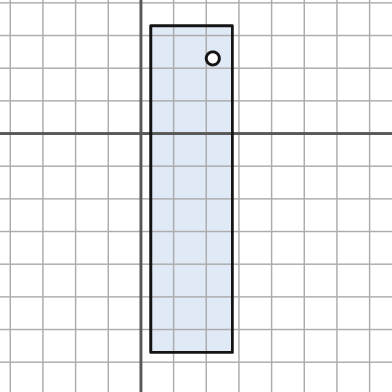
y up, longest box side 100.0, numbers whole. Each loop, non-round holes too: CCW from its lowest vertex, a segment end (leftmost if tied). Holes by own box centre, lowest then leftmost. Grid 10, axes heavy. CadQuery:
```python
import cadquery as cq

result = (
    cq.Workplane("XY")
    .moveTo(3.0, -67.0)
    .lineTo(28.0, -67.0)
    .lineTo(28.0, 33.0)
    .lineTo(3.0, 33.0)
    .close()
    .moveTo(22.0, 23.0)
    .circle(2.0)
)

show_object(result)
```